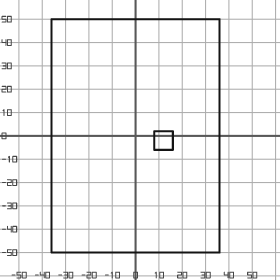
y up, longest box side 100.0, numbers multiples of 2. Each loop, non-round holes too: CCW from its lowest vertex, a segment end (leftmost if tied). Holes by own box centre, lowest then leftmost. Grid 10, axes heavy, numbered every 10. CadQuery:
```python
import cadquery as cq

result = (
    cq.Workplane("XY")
    .moveTo(-36.0, -50.0)
    .lineTo(36.0, -50.0)
    .lineTo(36.0, 50.0)
    .lineTo(-36.0, 50.0)
    .close()
    .moveTo(8.0, -6.0)
    .lineTo(16.0, -6.0)
    .lineTo(16.0, 2.0)
    .lineTo(8.0, 2.0)
    .close()
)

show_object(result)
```